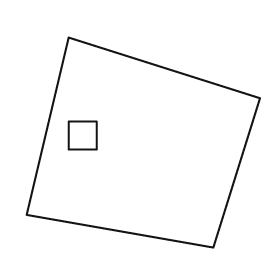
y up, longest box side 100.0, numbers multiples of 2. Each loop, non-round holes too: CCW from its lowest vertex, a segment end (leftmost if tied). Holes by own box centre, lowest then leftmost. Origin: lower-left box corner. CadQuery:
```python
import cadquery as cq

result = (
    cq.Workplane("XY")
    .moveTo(80.0, 0.0)
    .lineTo(100.0, 64.0)
    .lineTo(18.0, 90.0)
    .lineTo(0.0, 14.0)
    .close()
    .moveTo(18.0, 42.0)
    .lineTo(30.0, 42.0)
    .lineTo(30.0, 54.0)
    .lineTo(18.0, 54.0)
    .close()
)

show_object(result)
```